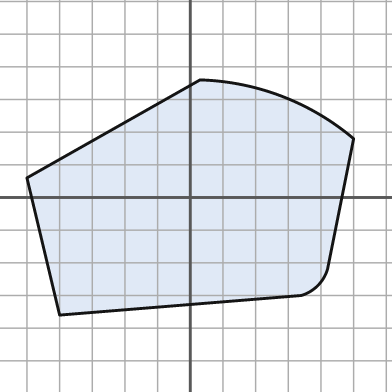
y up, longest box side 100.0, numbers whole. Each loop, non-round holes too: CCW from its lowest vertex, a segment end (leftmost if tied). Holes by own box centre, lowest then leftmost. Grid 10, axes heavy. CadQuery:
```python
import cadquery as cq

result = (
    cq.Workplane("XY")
    .moveTo(-40.0, -36.0)
    .lineTo(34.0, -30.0)
    .threePointArc((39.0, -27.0), (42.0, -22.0))
    .lineTo(50.0, 18.0)
    .threePointArc((28.0, 31.0), (3.0, 36.0))
    .lineTo(-50.0, 6.0)
    .close()
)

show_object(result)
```